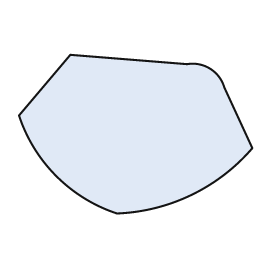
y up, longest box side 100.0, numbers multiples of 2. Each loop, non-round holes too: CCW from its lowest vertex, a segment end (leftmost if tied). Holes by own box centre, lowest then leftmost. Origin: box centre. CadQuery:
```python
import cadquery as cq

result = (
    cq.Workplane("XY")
    .moveTo(-8.0, -34.0)
    .threePointArc((24.0, -26.0), (50.0, -6.0))
    .lineTo(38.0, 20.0)
    .threePointArc((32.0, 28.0), (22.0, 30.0))
    .lineTo(-28.0, 34.0)
    .lineTo(-50.0, 8.0)
    .threePointArc((-34.0, -18.0), (-8.0, -34.0))
    .close()
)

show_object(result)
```